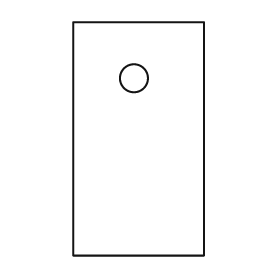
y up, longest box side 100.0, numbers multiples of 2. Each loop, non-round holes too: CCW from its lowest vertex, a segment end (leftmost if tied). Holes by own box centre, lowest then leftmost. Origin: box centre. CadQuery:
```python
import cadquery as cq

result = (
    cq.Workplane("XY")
    .moveTo(-28.0, -50.0)
    .lineTo(28.0, -50.0)
    .lineTo(28.0, 50.0)
    .lineTo(-28.0, 50.0)
    .close()
    .moveTo(-2.0, 26.0)
    .circle(6.0)
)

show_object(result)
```